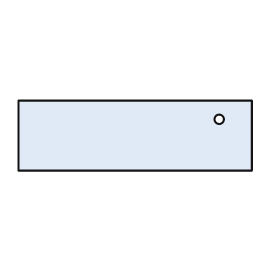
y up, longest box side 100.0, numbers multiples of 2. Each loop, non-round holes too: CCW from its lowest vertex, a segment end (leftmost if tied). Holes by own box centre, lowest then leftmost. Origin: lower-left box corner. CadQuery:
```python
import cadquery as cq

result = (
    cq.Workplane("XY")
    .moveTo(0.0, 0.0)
    .lineTo(100.0, 0.0)
    .lineTo(100.0, 30.0)
    .lineTo(0.0, 30.0)
    .close()
    .moveTo(86.0, 22.0)
    .circle(2.0)
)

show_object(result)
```